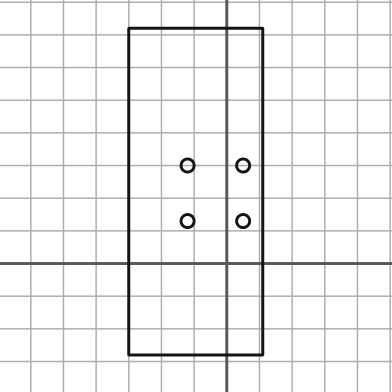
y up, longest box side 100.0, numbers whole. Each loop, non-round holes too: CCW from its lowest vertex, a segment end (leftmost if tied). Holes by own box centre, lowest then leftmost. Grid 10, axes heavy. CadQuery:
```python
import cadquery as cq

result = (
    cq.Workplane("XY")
    .moveTo(-30.0, -28.0)
    .lineTo(11.0, -28.0)
    .lineTo(11.0, 72.0)
    .lineTo(-30.0, 72.0)
    .close()
    .moveTo(-12.0, 13.0)
    .circle(2.0)
    .moveTo(5.0, 13.0)
    .circle(2.0)
    .moveTo(-12.0, 30.0)
    .circle(2.0)
    .moveTo(5.0, 30.0)
    .circle(2.0)
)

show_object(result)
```